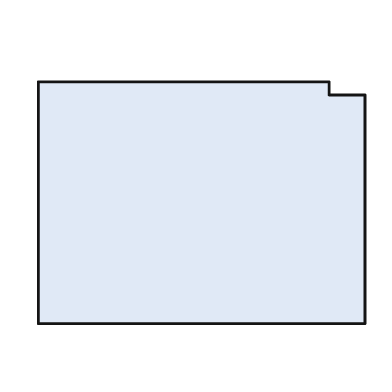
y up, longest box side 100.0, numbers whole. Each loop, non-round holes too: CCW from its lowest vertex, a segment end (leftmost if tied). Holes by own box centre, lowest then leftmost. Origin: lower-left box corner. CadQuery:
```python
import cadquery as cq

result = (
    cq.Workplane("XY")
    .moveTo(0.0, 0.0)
    .lineTo(100.0, 0.0)
    .lineTo(100.0, 70.0)
    .lineTo(89.0, 70.0)
    .lineTo(89.0, 74.0)
    .lineTo(0.0, 74.0)
    .close()
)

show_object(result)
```